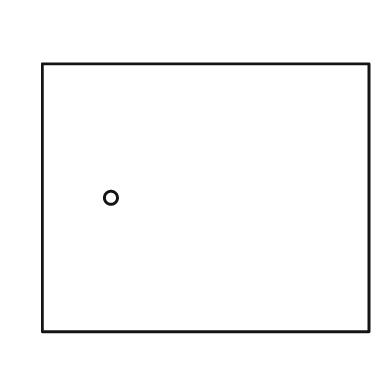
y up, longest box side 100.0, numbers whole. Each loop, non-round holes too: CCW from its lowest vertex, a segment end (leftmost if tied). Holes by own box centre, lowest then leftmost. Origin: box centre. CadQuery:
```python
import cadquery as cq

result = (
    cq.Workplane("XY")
    .moveTo(-50.0, -41.0)
    .lineTo(50.0, -41.0)
    .lineTo(50.0, 41.0)
    .lineTo(-50.0, 41.0)
    .close()
    .moveTo(-29.0, 0.0)
    .circle(2.0)
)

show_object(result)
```